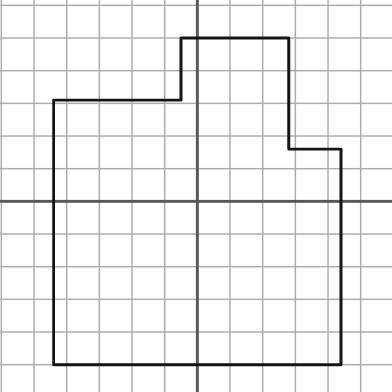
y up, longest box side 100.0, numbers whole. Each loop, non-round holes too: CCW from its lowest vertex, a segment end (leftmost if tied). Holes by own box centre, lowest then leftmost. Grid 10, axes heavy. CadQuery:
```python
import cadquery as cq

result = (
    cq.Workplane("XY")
    .moveTo(-44.0, -50.0)
    .lineTo(44.0, -50.0)
    .lineTo(44.0, 16.0)
    .lineTo(28.0, 16.0)
    .lineTo(28.0, 50.0)
    .lineTo(-5.0, 50.0)
    .lineTo(-5.0, 31.0)
    .lineTo(-44.0, 31.0)
    .close()
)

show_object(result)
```